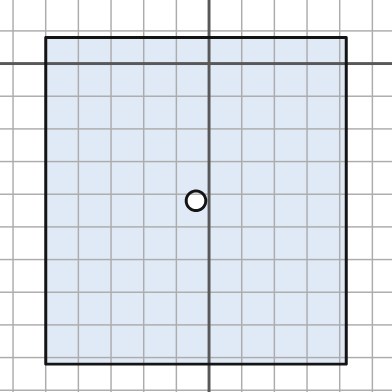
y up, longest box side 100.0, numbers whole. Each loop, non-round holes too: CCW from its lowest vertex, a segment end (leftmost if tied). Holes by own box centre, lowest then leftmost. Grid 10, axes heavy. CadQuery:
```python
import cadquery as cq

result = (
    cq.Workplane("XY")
    .moveTo(-50.0, -92.0)
    .lineTo(42.0, -92.0)
    .lineTo(42.0, 8.0)
    .lineTo(-50.0, 8.0)
    .close()
    .moveTo(-4.0, -42.0)
    .circle(3.0)
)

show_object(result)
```